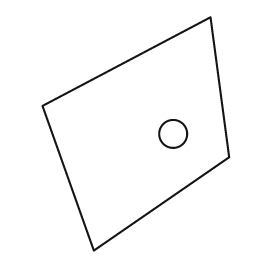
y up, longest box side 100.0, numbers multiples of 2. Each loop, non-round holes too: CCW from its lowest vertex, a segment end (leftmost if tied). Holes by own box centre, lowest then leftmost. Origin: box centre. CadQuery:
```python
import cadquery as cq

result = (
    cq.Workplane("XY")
    .moveTo(-18.0, -50.0)
    .lineTo(40.0, -10.0)
    .lineTo(32.0, 50.0)
    .lineTo(-40.0, 12.0)
    .close()
    .moveTo(16.0, 0.0)
    .circle(6.0)
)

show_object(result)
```